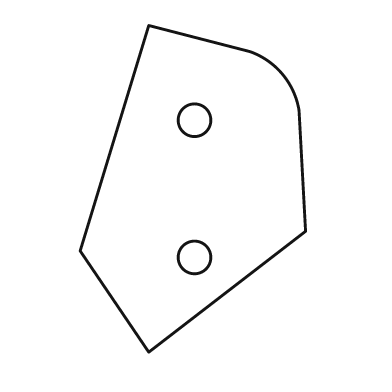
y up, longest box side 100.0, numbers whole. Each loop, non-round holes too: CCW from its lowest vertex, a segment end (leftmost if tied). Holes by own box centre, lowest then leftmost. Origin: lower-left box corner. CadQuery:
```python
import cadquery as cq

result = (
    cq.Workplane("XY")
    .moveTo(21.0, 0.0)
    .lineTo(69.0, 37.0)
    .lineTo(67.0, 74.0)
    .threePointArc((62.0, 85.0), (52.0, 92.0))
    .lineTo(21.0, 100.0)
    .lineTo(0.0, 31.0)
    .close()
    .moveTo(35.0, 29.0)
    .circle(5.0)
    .moveTo(35.0, 71.0)
    .circle(5.0)
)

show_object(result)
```